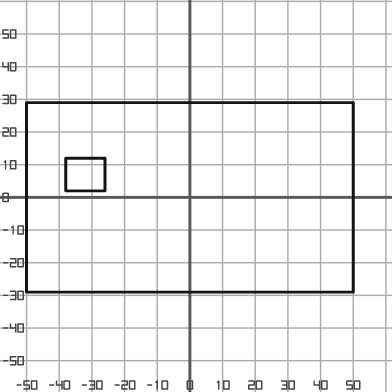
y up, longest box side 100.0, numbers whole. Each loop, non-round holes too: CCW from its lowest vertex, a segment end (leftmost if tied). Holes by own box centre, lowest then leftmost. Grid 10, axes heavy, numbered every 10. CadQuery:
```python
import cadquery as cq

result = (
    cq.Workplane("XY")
    .moveTo(-50.0, -29.0)
    .lineTo(50.0, -29.0)
    .lineTo(50.0, 29.0)
    .lineTo(-50.0, 29.0)
    .close()
    .moveTo(-38.0, 2.0)
    .lineTo(-26.0, 2.0)
    .lineTo(-26.0, 12.0)
    .lineTo(-38.0, 12.0)
    .close()
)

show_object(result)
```